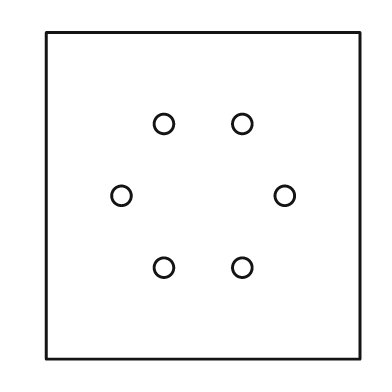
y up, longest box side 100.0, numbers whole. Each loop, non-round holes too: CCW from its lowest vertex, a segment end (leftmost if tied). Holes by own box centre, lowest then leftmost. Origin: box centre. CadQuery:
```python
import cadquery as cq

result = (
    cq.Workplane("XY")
    .moveTo(-48.0, -50.0)
    .lineTo(48.0, -50.0)
    .lineTo(48.0, 50.0)
    .lineTo(-48.0, 50.0)
    .close()
    .moveTo(-12.0, -22.0)
    .circle(3.0)
    .moveTo(12.0, -22.0)
    .circle(3.0)
    .moveTo(-25.0, 0.0)
    .circle(3.0)
    .moveTo(25.0, 0.0)
    .circle(3.0)
    .moveTo(-12.0, 22.0)
    .circle(3.0)
    .moveTo(12.0, 22.0)
    .circle(3.0)
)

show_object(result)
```